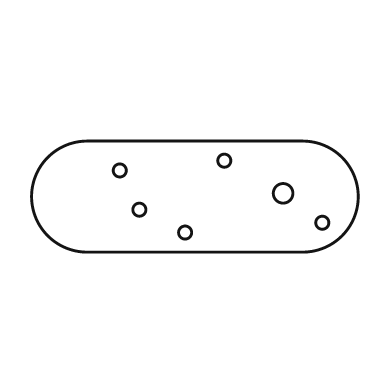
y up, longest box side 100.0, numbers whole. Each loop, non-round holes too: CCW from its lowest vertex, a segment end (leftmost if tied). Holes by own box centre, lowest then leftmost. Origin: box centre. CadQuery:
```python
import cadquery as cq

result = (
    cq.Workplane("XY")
    .moveTo(-33.0, -17.0)
    .lineTo(33.0, -17.0)
    .threePointArc((50.0, 0.0), (33.0, 17.0))
    .lineTo(-33.0, 17.0)
    .threePointArc((-50.0, 0.0), (-33.0, -17.0))
    .close()
    .moveTo(-3.0, -11.0)
    .circle(2.0)
    .moveTo(39.0, -8.0)
    .circle(2.0)
    .moveTo(-17.0, -4.0)
    .circle(2.0)
    .moveTo(27.0, 1.0)
    .circle(3.0)
    .moveTo(-23.0, 8.0)
    .circle(2.0)
    .moveTo(9.0, 11.0)
    .circle(2.0)
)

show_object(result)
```